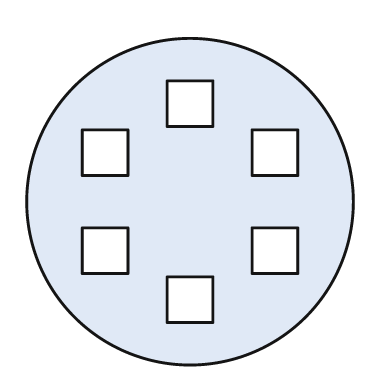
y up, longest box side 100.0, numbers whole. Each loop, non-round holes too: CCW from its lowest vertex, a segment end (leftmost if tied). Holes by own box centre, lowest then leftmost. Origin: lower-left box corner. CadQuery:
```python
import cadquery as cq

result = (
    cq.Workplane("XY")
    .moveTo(50.0, 50.0)
    .circle(50.0)
    .moveTo(43.0, 13.0)
    .lineTo(57.0, 13.0)
    .lineTo(57.0, 27.0)
    .lineTo(43.0, 27.0)
    .close()
    .moveTo(17.0, 28.0)
    .lineTo(31.0, 28.0)
    .lineTo(31.0, 42.0)
    .lineTo(17.0, 42.0)
    .close()
    .moveTo(69.0, 28.0)
    .lineTo(83.0, 28.0)
    .lineTo(83.0, 42.0)
    .lineTo(69.0, 42.0)
    .close()
    .moveTo(17.0, 58.0)
    .lineTo(31.0, 58.0)
    .lineTo(31.0, 72.0)
    .lineTo(17.0, 72.0)
    .close()
    .moveTo(69.0, 58.0)
    .lineTo(83.0, 58.0)
    .lineTo(83.0, 72.0)
    .lineTo(69.0, 72.0)
    .close()
    .moveTo(43.0, 73.0)
    .lineTo(57.0, 73.0)
    .lineTo(57.0, 87.0)
    .lineTo(43.0, 87.0)
    .close()
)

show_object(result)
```